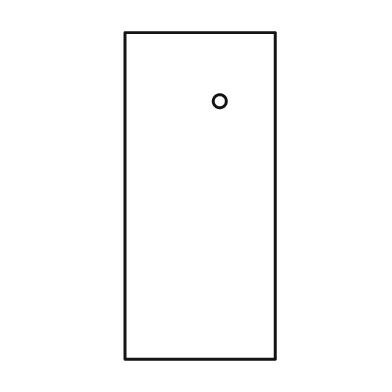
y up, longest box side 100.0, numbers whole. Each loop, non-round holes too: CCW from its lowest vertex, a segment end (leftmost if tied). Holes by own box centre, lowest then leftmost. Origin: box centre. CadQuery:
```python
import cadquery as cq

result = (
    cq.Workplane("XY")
    .moveTo(-23.0, -50.0)
    .lineTo(23.0, -50.0)
    .lineTo(23.0, 50.0)
    .lineTo(-23.0, 50.0)
    .close()
    .moveTo(6.0, 29.0)
    .circle(2.0)
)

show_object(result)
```